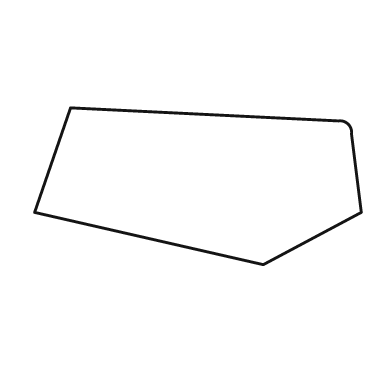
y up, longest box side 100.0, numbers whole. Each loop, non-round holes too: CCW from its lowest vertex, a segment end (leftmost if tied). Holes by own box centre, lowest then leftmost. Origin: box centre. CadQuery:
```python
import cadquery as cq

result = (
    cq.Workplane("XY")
    .moveTo(20.0, -24.0)
    .lineTo(50.0, -8.0)
    .lineTo(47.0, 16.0)
    .threePointArc((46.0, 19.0), (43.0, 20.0))
    .lineTo(-39.0, 24.0)
    .lineTo(-50.0, -8.0)
    .close()
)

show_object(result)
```